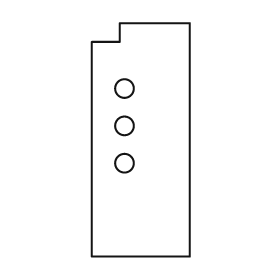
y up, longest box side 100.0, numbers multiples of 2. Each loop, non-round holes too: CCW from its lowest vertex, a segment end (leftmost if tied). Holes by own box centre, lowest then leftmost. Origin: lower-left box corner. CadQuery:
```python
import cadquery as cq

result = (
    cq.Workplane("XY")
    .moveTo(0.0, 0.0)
    .lineTo(42.0, 0.0)
    .lineTo(42.0, 100.0)
    .lineTo(12.0, 100.0)
    .lineTo(12.0, 92.0)
    .lineTo(0.0, 92.0)
    .close()
    .moveTo(14.0, 40.0)
    .circle(4.0)
    .moveTo(14.0, 56.0)
    .circle(4.0)
    .moveTo(14.0, 72.0)
    .circle(4.0)
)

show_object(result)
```